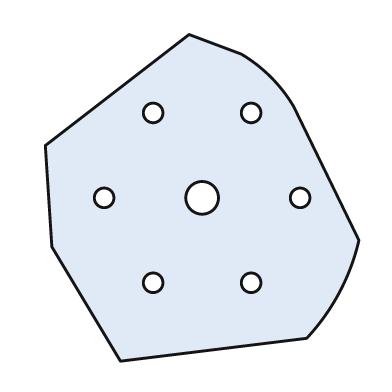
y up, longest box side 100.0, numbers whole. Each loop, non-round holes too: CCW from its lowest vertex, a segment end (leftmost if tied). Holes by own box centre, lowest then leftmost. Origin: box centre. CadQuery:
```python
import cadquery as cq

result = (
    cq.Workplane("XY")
    .moveTo(-25.0, -50.0)
    .lineTo(32.0, -43.0)
    .threePointArc((42.0, -29.0), (48.0, -13.0))
    .lineTo(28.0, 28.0)
    .threePointArc((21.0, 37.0), (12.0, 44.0))
    .lineTo(-4.0, 50.0)
    .lineTo(-48.0, 16.0)
    .lineTo(-46.0, -15.0)
    .close()
    .moveTo(-15.0, -26.0)
    .circle(3.0)
    .moveTo(15.0, -26.0)
    .circle(3.0)
    .moveTo(-30.0, 0.0)
    .circle(3.0)
    .moveTo(0.0, 0.0)
    .circle(5.0)
    .moveTo(30.0, 0.0)
    .circle(3.0)
    .moveTo(-15.0, 26.0)
    .circle(3.0)
    .moveTo(15.0, 26.0)
    .circle(3.0)
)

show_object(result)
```